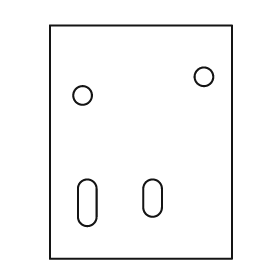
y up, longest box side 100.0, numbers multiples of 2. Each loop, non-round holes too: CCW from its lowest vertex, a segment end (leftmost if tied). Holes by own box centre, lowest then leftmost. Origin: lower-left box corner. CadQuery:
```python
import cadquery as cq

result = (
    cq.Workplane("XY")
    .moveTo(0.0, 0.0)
    .lineTo(78.0, 0.0)
    .lineTo(78.0, 100.0)
    .lineTo(0.0, 100.0)
    .close()
    .moveTo(12.0, 18.0)
    .threePointArc((16.0, 14.0), (20.0, 18.0))
    .lineTo(20.0, 30.0)
    .threePointArc((16.0, 34.0), (12.0, 30.0))
    .close()
    .moveTo(40.0, 22.0)
    .threePointArc((44.0, 18.0), (48.0, 22.0))
    .lineTo(48.0, 30.0)
    .threePointArc((44.0, 34.0), (40.0, 30.0))
    .close()
    .moveTo(14.0, 70.0)
    .circle(4.0)
    .moveTo(66.0, 78.0)
    .circle(4.0)
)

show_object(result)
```